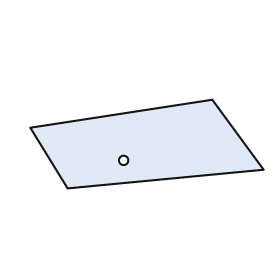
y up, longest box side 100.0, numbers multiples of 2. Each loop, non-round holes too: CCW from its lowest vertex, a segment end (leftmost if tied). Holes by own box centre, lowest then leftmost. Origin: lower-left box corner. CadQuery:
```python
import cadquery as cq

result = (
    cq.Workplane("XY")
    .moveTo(16.0, 0.0)
    .lineTo(100.0, 8.0)
    .lineTo(78.0, 38.0)
    .lineTo(0.0, 26.0)
    .close()
    .moveTo(40.0, 12.0)
    .circle(2.0)
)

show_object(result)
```